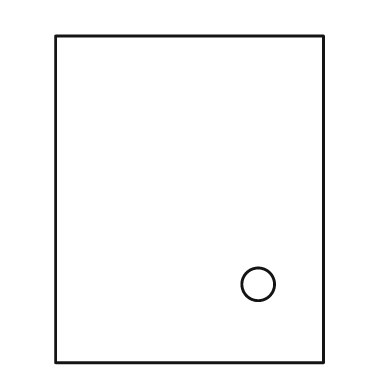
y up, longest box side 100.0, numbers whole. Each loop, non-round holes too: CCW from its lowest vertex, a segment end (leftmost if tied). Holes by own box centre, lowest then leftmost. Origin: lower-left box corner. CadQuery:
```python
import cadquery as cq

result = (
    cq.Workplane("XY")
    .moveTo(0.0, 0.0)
    .lineTo(82.0, 0.0)
    .lineTo(82.0, 100.0)
    .lineTo(0.0, 100.0)
    .close()
    .moveTo(62.0, 24.0)
    .circle(5.0)
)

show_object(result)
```